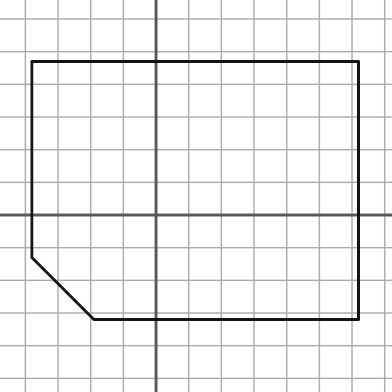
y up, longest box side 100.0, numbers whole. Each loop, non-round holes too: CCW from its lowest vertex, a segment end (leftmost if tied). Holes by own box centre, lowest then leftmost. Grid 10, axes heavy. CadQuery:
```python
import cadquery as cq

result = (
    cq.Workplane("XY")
    .moveTo(-19.0, -32.0)
    .lineTo(62.0, -32.0)
    .lineTo(62.0, 47.0)
    .lineTo(-38.0, 47.0)
    .lineTo(-38.0, -13.0)
    .close()
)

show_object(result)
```